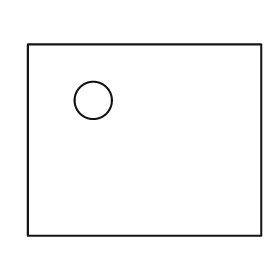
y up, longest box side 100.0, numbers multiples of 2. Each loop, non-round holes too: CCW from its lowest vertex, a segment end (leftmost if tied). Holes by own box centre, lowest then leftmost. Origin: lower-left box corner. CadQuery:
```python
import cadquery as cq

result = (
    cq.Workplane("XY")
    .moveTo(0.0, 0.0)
    .lineTo(100.0, 0.0)
    .lineTo(100.0, 82.0)
    .lineTo(0.0, 82.0)
    .close()
    .moveTo(28.0, 58.0)
    .circle(8.0)
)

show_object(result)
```